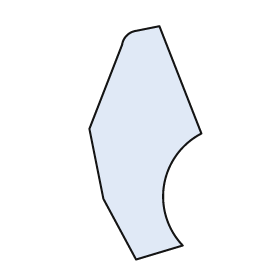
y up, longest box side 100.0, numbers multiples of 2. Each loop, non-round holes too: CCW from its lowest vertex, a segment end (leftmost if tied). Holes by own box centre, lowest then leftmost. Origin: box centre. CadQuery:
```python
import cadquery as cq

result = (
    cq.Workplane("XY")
    .moveTo(-4.0, -50.0)
    .lineTo(16.0, -44.0)
    .threePointArc((8.0, -18.0), (24.0, 4.0))
    .lineTo(6.0, 50.0)
    .lineTo(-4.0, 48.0)
    .threePointArc((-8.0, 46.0), (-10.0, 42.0))
    .lineTo(-24.0, 6.0)
    .lineTo(-18.0, -24.0)
    .close()
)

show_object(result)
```